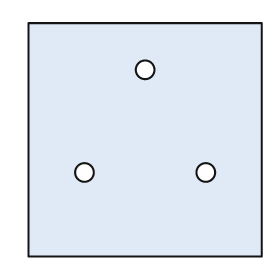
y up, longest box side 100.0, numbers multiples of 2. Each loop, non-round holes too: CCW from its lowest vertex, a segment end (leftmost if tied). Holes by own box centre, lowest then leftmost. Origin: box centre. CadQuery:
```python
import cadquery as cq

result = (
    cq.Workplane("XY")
    .moveTo(-50.0, -50.0)
    .lineTo(50.0, -50.0)
    .lineTo(50.0, 50.0)
    .lineTo(-50.0, 50.0)
    .close()
    .moveTo(-26.0, -14.0)
    .circle(4.0)
    .moveTo(26.0, -14.0)
    .circle(4.0)
    .moveTo(0.0, 30.0)
    .circle(4.0)
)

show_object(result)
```